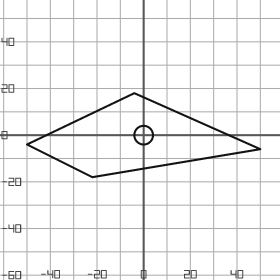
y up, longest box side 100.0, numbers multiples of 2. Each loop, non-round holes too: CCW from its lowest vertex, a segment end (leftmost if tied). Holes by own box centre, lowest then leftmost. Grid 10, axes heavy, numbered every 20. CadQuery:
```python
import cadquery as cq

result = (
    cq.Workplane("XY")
    .moveTo(-22.0, -18.0)
    .lineTo(50.0, -6.0)
    .lineTo(-4.0, 18.0)
    .lineTo(-50.0, -4.0)
    .close()
    .moveTo(0.0, 0.0)
    .circle(4.0)
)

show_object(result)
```